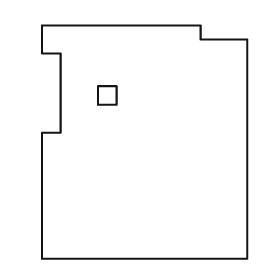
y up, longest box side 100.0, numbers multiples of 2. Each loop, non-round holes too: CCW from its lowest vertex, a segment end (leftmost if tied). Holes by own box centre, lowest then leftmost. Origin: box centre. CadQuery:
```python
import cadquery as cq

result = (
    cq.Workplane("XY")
    .moveTo(-44.0, -50.0)
    .lineTo(44.0, -50.0)
    .lineTo(44.0, 44.0)
    .lineTo(24.0, 44.0)
    .lineTo(24.0, 50.0)
    .lineTo(-44.0, 50.0)
    .lineTo(-44.0, 38.0)
    .lineTo(-36.0, 38.0)
    .lineTo(-36.0, 4.0)
    .lineTo(-44.0, 4.0)
    .close()
    .moveTo(-20.0, 16.0)
    .lineTo(-12.0, 16.0)
    .lineTo(-12.0, 24.0)
    .lineTo(-20.0, 24.0)
    .close()
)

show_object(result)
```